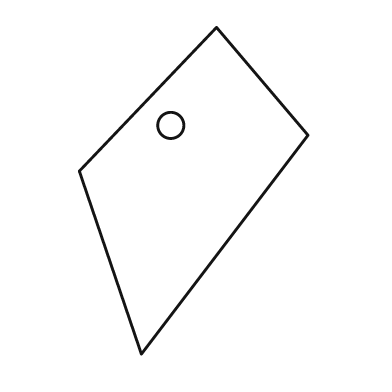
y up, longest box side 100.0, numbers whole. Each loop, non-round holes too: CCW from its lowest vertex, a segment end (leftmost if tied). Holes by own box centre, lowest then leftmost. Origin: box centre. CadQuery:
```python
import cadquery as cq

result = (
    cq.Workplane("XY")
    .moveTo(-16.0, -50.0)
    .lineTo(35.0, 17.0)
    .lineTo(7.0, 50.0)
    .lineTo(-35.0, 6.0)
    .close()
    .moveTo(-7.0, 20.0)
    .circle(4.0)
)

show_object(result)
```